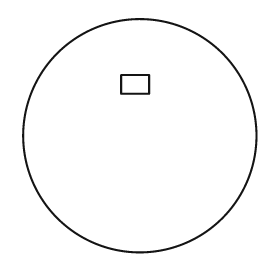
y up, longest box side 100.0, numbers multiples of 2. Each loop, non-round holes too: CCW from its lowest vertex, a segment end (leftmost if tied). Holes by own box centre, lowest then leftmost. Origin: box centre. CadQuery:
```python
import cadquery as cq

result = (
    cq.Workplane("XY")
    .moveTo(0.0, 0.0)
    .circle(50.0)
    .moveTo(-8.0, 18.0)
    .lineTo(4.0, 18.0)
    .lineTo(4.0, 26.0)
    .lineTo(-8.0, 26.0)
    .close()
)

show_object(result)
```